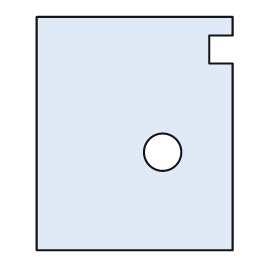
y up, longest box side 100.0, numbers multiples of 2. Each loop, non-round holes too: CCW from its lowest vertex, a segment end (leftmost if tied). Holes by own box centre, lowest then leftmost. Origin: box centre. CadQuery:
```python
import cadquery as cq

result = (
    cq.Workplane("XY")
    .moveTo(-42.0, -50.0)
    .lineTo(42.0, -50.0)
    .lineTo(42.0, 30.0)
    .lineTo(32.0, 30.0)
    .lineTo(32.0, 42.0)
    .lineTo(42.0, 42.0)
    .lineTo(42.0, 50.0)
    .lineTo(-42.0, 50.0)
    .close()
    .moveTo(12.0, -8.0)
    .circle(8.0)
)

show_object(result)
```